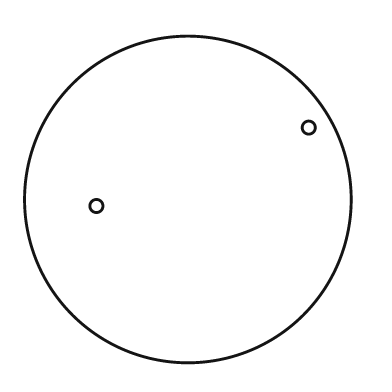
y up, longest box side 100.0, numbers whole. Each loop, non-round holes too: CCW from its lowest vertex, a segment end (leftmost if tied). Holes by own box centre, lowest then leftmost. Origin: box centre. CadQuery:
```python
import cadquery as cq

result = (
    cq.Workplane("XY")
    .moveTo(0.0, 0.0)
    .circle(50.0)
    .moveTo(-28.0, -2.0)
    .circle(2.0)
    .moveTo(37.0, 22.0)
    .circle(2.0)
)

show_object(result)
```